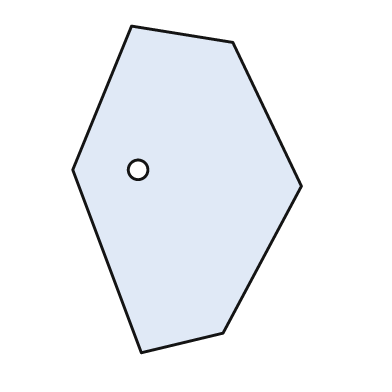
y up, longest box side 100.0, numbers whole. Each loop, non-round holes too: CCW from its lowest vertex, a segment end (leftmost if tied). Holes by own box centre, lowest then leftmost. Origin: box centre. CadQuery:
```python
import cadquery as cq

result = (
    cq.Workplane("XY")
    .moveTo(-14.0, -50.0)
    .lineTo(11.0, -44.0)
    .lineTo(35.0, 1.0)
    .lineTo(14.0, 45.0)
    .lineTo(-17.0, 50.0)
    .lineTo(-35.0, 6.0)
    .close()
    .moveTo(-15.0, 6.0)
    .circle(3.0)
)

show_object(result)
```